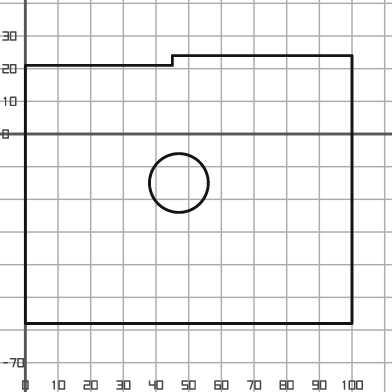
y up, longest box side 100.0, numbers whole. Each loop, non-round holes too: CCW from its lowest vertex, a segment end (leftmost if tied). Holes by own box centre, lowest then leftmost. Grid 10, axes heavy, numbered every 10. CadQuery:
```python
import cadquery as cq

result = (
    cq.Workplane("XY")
    .moveTo(0.0, -58.0)
    .lineTo(100.0, -58.0)
    .lineTo(100.0, 24.0)
    .lineTo(45.0, 24.0)
    .lineTo(45.0, 21.0)
    .lineTo(0.0, 21.0)
    .close()
    .moveTo(47.0, -15.0)
    .circle(9.0)
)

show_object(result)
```